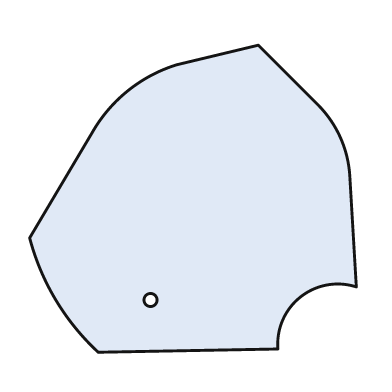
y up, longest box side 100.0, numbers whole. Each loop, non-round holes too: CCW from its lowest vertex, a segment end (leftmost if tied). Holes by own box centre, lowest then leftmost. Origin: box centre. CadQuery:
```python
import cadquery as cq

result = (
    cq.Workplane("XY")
    .moveTo(-29.0, -47.0)
    .lineTo(26.0, -46.0)
    .threePointArc((33.0, -30.0), (50.0, -27.0))
    .lineTo(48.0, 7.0)
    .threePointArc((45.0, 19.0), (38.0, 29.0))
    .lineTo(20.0, 47.0)
    .lineTo(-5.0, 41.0)
    .threePointArc((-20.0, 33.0), (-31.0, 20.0))
    .lineTo(-50.0, -12.0)
    .threePointArc((-42.0, -31.0), (-29.0, -47.0))
    .close()
    .moveTo(-13.0, -31.0)
    .circle(2.0)
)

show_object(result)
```